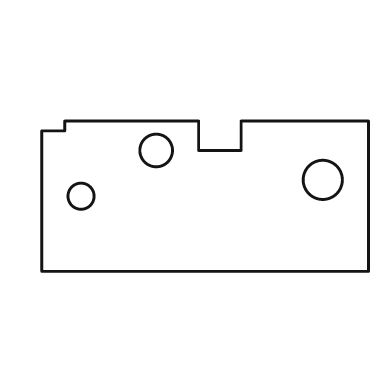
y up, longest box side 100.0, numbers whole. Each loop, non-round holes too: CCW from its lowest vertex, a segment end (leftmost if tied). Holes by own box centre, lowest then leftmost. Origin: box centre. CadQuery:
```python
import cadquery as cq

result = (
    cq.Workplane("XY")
    .moveTo(-50.0, -23.0)
    .lineTo(50.0, -23.0)
    .lineTo(50.0, 23.0)
    .lineTo(11.0, 23.0)
    .lineTo(11.0, 14.0)
    .lineTo(-2.0, 14.0)
    .lineTo(-2.0, 23.0)
    .lineTo(-43.0, 23.0)
    .lineTo(-43.0, 20.0)
    .lineTo(-50.0, 20.0)
    .close()
    .moveTo(-38.0, 0.0)
    .circle(4.0)
    .moveTo(36.0, 5.0)
    .circle(6.0)
    .moveTo(-15.0, 14.0)
    .circle(5.0)
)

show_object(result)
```